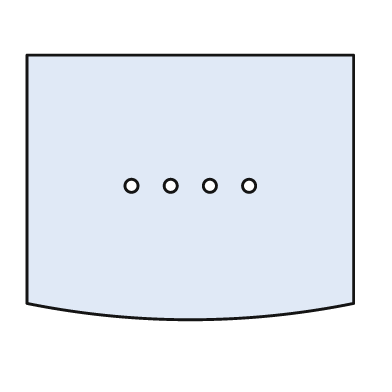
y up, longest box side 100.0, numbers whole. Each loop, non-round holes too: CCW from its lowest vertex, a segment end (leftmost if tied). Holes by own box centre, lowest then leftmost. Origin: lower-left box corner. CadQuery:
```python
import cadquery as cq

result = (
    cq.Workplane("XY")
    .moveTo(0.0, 5.0)
    .threePointArc((50.0, 0.0), (100.0, 5.0))
    .lineTo(100.0, 81.0)
    .lineTo(0.0, 81.0)
    .close()
    .moveTo(32.0, 41.0)
    .circle(2.0)
    .moveTo(44.0, 41.0)
    .circle(2.0)
    .moveTo(56.0, 41.0)
    .circle(2.0)
    .moveTo(68.0, 41.0)
    .circle(2.0)
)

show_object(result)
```